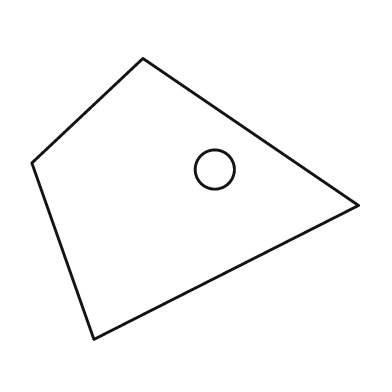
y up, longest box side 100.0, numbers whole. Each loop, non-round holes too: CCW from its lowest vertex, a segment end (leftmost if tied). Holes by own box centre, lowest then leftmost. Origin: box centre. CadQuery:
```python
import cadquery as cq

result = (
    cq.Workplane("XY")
    .moveTo(-31.0, -43.0)
    .lineTo(50.0, -2.0)
    .lineTo(-16.0, 43.0)
    .lineTo(-50.0, 11.0)
    .close()
    .moveTo(6.0, 9.0)
    .circle(6.0)
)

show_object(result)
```